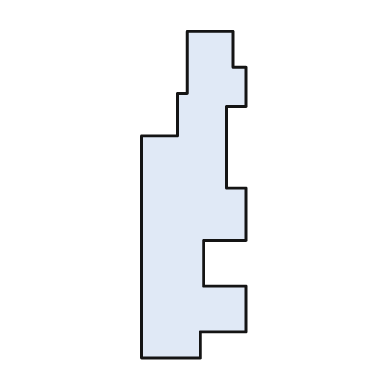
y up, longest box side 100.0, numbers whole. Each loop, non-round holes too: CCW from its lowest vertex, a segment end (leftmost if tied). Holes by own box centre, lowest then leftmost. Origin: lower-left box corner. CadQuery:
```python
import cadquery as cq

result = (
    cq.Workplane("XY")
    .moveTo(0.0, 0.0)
    .lineTo(18.0, 0.0)
    .lineTo(18.0, 8.0)
    .lineTo(32.0, 8.0)
    .lineTo(32.0, 22.0)
    .lineTo(19.0, 22.0)
    .lineTo(19.0, 36.0)
    .lineTo(32.0, 36.0)
    .lineTo(32.0, 52.0)
    .lineTo(26.0, 52.0)
    .lineTo(26.0, 77.0)
    .lineTo(32.0, 77.0)
    .lineTo(32.0, 89.0)
    .lineTo(28.0, 89.0)
    .lineTo(28.0, 100.0)
    .lineTo(14.0, 100.0)
    .lineTo(14.0, 81.0)
    .lineTo(11.0, 81.0)
    .lineTo(11.0, 68.0)
    .lineTo(0.0, 68.0)
    .close()
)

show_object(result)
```